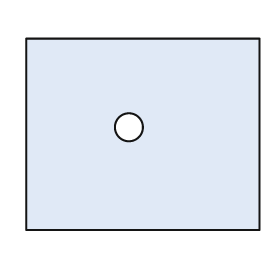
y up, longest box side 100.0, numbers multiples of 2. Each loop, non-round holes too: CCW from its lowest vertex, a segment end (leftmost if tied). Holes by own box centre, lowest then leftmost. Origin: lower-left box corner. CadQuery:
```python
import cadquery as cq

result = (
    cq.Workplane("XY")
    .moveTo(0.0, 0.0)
    .lineTo(100.0, 0.0)
    .lineTo(100.0, 82.0)
    .lineTo(0.0, 82.0)
    .close()
    .moveTo(44.0, 44.0)
    .circle(6.0)
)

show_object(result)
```